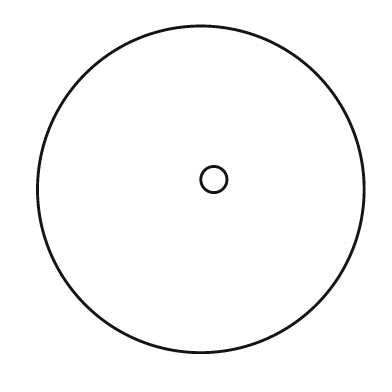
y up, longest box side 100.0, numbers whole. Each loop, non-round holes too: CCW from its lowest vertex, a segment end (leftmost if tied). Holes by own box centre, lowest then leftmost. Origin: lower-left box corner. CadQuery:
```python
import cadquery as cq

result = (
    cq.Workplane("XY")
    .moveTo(50.0, 50.0)
    .circle(50.0)
    .moveTo(54.0, 53.0)
    .circle(4.0)
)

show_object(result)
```